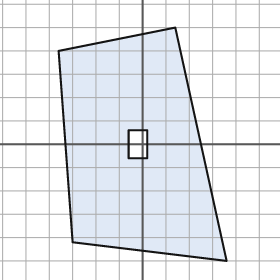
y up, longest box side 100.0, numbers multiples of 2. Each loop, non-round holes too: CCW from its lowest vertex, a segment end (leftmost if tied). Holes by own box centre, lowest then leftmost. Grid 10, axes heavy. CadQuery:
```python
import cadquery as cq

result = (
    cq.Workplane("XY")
    .moveTo(36.0, -50.0)
    .lineTo(14.0, 50.0)
    .lineTo(-36.0, 40.0)
    .lineTo(-30.0, -42.0)
    .close()
    .moveTo(-6.0, -6.0)
    .lineTo(2.0, -6.0)
    .lineTo(2.0, 6.0)
    .lineTo(-6.0, 6.0)
    .close()
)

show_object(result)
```